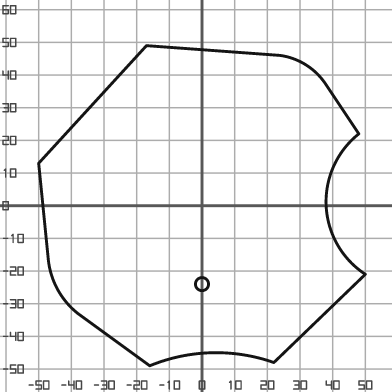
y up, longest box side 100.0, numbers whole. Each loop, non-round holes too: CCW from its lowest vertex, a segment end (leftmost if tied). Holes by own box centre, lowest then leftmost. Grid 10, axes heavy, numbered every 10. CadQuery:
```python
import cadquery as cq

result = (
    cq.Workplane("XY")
    .moveTo(-16.0, -49.0)
    .threePointArc((3.0, -45.0), (22.0, -48.0))
    .lineTo(50.0, -21.0)
    .threePointArc((38.0, 0.0), (48.0, 22.0))
    .lineTo(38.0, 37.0)
    .threePointArc((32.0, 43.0), (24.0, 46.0))
    .lineTo(-17.0, 49.0)
    .lineTo(-50.0, 13.0)
    .lineTo(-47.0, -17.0)
    .threePointArc((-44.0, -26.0), (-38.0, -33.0))
    .close()
    .moveTo(0.0, -24.0)
    .circle(2.0)
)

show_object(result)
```